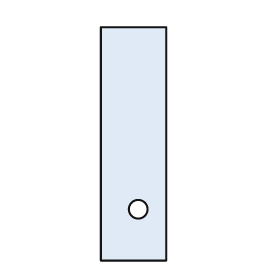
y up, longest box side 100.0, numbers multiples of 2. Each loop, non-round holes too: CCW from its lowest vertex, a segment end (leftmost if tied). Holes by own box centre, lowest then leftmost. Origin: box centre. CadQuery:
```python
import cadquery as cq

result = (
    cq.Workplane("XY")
    .moveTo(-14.0, -50.0)
    .lineTo(14.0, -50.0)
    .lineTo(14.0, 50.0)
    .lineTo(-14.0, 50.0)
    .close()
    .moveTo(2.0, -28.0)
    .circle(4.0)
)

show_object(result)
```